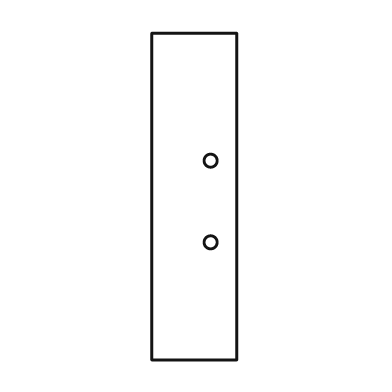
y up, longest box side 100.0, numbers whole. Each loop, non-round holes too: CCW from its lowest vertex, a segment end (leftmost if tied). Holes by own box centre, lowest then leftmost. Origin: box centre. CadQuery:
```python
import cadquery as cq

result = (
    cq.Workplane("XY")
    .moveTo(-13.0, -50.0)
    .lineTo(13.0, -50.0)
    .lineTo(13.0, 50.0)
    .lineTo(-13.0, 50.0)
    .close()
    .moveTo(5.0, -14.0)
    .circle(2.0)
    .moveTo(5.0, 11.0)
    .circle(2.0)
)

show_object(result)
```